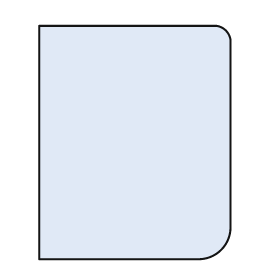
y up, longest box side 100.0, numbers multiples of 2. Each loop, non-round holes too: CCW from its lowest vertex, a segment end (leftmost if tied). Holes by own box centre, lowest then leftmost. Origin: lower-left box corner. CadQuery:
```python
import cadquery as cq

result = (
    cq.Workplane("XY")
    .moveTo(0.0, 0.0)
    .lineTo(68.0, 0.0)
    .threePointArc((78.0, 4.0), (82.0, 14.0))
    .lineTo(82.0, 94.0)
    .threePointArc((80.0, 98.0), (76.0, 100.0))
    .lineTo(0.0, 100.0)
    .close()
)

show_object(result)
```